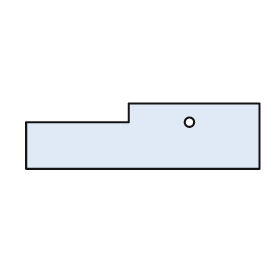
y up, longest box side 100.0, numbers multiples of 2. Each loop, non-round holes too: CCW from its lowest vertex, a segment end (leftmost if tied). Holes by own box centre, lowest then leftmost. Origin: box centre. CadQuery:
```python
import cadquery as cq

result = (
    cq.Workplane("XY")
    .moveTo(-50.0, -14.0)
    .lineTo(50.0, -14.0)
    .lineTo(50.0, 14.0)
    .lineTo(-6.0, 14.0)
    .lineTo(-6.0, 6.0)
    .lineTo(-50.0, 6.0)
    .close()
    .moveTo(20.0, 6.0)
    .circle(2.0)
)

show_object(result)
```